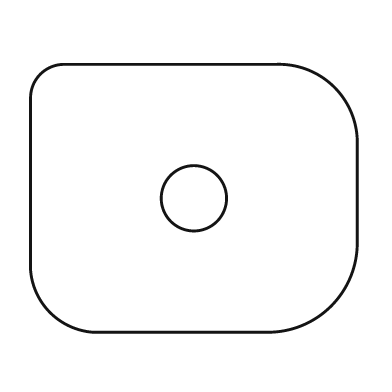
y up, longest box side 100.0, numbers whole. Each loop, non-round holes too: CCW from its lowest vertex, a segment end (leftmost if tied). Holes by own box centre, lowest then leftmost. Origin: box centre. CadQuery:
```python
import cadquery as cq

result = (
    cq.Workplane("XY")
    .moveTo(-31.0, -41.0)
    .lineTo(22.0, -41.0)
    .threePointArc((42.0, -33.0), (50.0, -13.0))
    .lineTo(50.0, 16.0)
    .threePointArc((43.0, 34.0), (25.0, 41.0))
    .lineTo(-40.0, 41.0)
    .threePointArc((-47.0, 38.0), (-50.0, 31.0))
    .lineTo(-50.0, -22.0)
    .threePointArc((-44.0, -35.0), (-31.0, -41.0))
    .close()
    .moveTo(0.0, 0.0)
    .circle(10.0)
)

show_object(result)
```